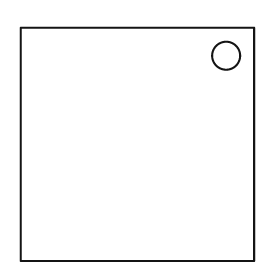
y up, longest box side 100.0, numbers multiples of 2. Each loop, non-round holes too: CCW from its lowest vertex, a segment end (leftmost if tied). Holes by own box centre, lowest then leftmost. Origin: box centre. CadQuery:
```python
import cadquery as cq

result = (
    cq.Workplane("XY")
    .moveTo(-50.0, -50.0)
    .lineTo(50.0, -50.0)
    .lineTo(50.0, 50.0)
    .lineTo(-50.0, 50.0)
    .close()
    .moveTo(38.0, 38.0)
    .circle(6.0)
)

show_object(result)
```